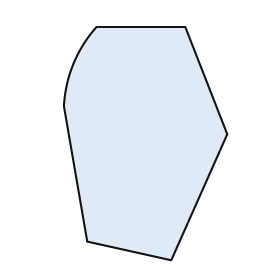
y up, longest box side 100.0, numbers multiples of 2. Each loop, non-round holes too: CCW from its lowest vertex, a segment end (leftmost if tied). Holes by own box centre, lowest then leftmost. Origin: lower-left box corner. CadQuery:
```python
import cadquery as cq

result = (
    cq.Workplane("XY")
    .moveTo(46.0, 0.0)
    .lineTo(70.0, 54.0)
    .lineTo(52.0, 100.0)
    .lineTo(14.0, 100.0)
    .threePointArc((4.0, 84.0), (0.0, 66.0))
    .lineTo(10.0, 8.0)
    .close()
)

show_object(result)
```